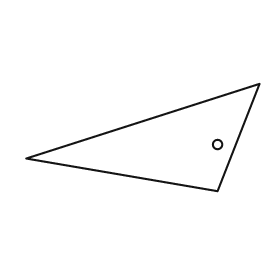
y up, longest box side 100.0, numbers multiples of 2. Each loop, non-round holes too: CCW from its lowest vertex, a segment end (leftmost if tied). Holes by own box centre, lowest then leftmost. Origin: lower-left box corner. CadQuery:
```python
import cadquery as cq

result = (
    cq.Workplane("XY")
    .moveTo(82.0, 0.0)
    .lineTo(100.0, 46.0)
    .lineTo(0.0, 14.0)
    .close()
    .moveTo(82.0, 20.0)
    .circle(2.0)
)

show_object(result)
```